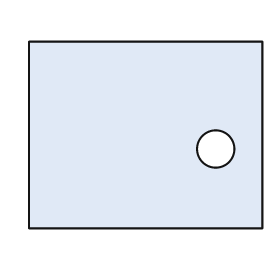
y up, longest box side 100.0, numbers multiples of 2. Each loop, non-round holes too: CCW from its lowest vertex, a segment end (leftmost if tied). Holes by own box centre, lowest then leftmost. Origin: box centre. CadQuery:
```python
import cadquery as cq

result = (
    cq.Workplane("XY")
    .moveTo(-50.0, -40.0)
    .lineTo(50.0, -40.0)
    .lineTo(50.0, 40.0)
    .lineTo(-50.0, 40.0)
    .close()
    .moveTo(30.0, -6.0)
    .circle(8.0)
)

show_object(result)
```